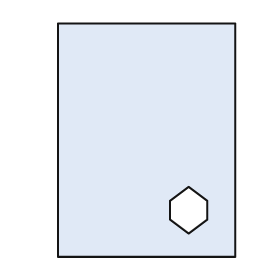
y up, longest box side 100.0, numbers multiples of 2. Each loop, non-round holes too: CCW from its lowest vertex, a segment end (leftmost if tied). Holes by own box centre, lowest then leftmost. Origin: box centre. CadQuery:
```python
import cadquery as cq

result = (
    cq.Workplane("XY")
    .moveTo(-38.0, -50.0)
    .lineTo(38.0, -50.0)
    .lineTo(38.0, 50.0)
    .lineTo(-38.0, 50.0)
    .close()
    .moveTo(18.0, -40.0)
    .lineTo(26.0, -34.0)
    .lineTo(26.0, -26.0)
    .lineTo(18.0, -20.0)
    .lineTo(10.0, -26.0)
    .lineTo(10.0, -34.0)
    .close()
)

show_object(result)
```